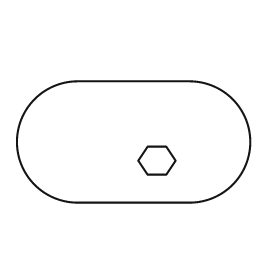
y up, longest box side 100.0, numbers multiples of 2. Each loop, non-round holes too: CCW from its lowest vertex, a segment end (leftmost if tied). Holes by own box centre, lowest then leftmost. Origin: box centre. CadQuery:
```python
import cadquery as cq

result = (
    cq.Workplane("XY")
    .moveTo(-24.0, -26.0)
    .lineTo(24.0, -26.0)
    .threePointArc((50.0, 0.0), (24.0, 26.0))
    .lineTo(-24.0, 26.0)
    .threePointArc((-50.0, 0.0), (-24.0, -26.0))
    .close()
    .moveTo(6.0, -14.0)
    .lineTo(14.0, -14.0)
    .lineTo(18.0, -8.0)
    .lineTo(14.0, -2.0)
    .lineTo(6.0, -2.0)
    .lineTo(2.0, -8.0)
    .close()
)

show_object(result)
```